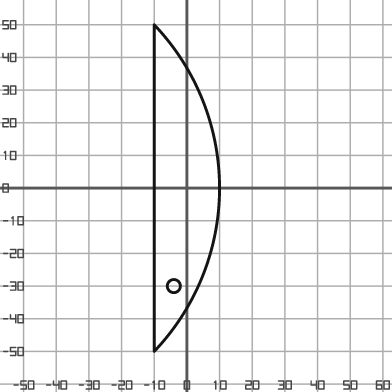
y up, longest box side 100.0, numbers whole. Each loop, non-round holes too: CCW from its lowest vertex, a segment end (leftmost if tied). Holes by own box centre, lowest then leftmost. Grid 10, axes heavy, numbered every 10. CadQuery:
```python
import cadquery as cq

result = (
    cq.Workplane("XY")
    .moveTo(-10.0, -50.0)
    .threePointArc((10.0, 0.0), (-10.0, 50.0))
    .close()
    .moveTo(-4.0, -30.0)
    .circle(2.0)
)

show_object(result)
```